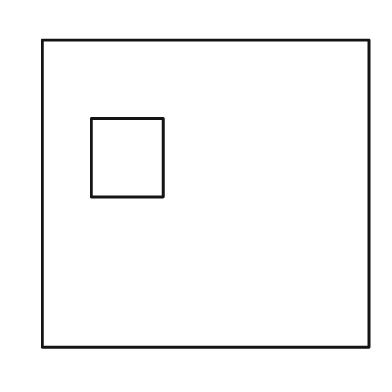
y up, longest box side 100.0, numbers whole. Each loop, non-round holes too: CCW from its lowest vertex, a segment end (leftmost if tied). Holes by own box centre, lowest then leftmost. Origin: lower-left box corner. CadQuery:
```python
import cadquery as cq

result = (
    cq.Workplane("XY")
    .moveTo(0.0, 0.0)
    .lineTo(100.0, 0.0)
    .lineTo(100.0, 94.0)
    .lineTo(0.0, 94.0)
    .close()
    .moveTo(15.0, 46.0)
    .lineTo(37.0, 46.0)
    .lineTo(37.0, 70.0)
    .lineTo(15.0, 70.0)
    .close()
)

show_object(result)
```